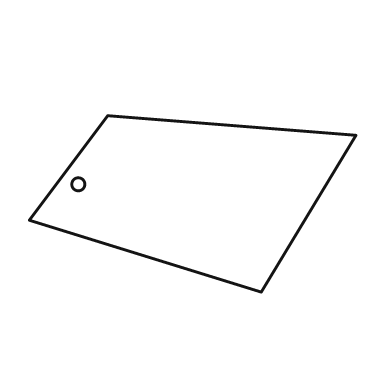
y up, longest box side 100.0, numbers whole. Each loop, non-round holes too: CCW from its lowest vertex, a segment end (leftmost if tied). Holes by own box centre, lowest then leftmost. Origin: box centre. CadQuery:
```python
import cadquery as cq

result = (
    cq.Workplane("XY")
    .moveTo(21.0, -27.0)
    .lineTo(50.0, 21.0)
    .lineTo(-26.0, 27.0)
    .lineTo(-50.0, -5.0)
    .close()
    .moveTo(-35.0, 6.0)
    .circle(2.0)
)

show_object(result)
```